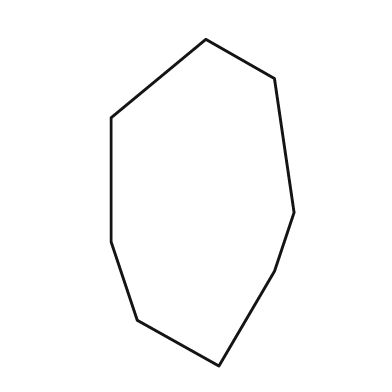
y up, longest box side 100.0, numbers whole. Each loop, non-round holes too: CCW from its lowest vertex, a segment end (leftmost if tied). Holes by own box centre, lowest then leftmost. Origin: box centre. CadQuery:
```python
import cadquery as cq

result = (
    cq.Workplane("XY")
    .moveTo(5.0, -50.0)
    .lineTo(22.0, -21.0)
    .lineTo(28.0, -3.0)
    .lineTo(22.0, 38.0)
    .lineTo(1.0, 50.0)
    .lineTo(-28.0, 26.0)
    .lineTo(-28.0, -12.0)
    .lineTo(-20.0, -36.0)
    .close()
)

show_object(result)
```